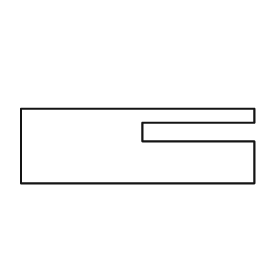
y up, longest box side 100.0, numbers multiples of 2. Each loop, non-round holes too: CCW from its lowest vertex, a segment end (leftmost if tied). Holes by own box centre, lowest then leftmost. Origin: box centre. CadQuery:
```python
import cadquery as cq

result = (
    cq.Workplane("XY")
    .moveTo(-50.0, -16.0)
    .lineTo(50.0, -16.0)
    .lineTo(50.0, 2.0)
    .lineTo(2.0, 2.0)
    .lineTo(2.0, 10.0)
    .lineTo(50.0, 10.0)
    .lineTo(50.0, 16.0)
    .lineTo(-50.0, 16.0)
    .close()
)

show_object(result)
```